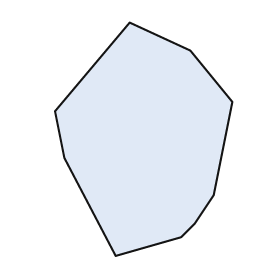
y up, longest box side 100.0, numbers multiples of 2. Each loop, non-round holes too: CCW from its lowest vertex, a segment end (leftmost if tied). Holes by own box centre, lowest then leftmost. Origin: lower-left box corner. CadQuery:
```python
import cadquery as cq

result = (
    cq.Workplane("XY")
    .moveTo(26.0, 0.0)
    .lineTo(54.0, 8.0)
    .lineTo(60.0, 14.0)
    .lineTo(68.0, 26.0)
    .lineTo(76.0, 66.0)
    .lineTo(58.0, 88.0)
    .lineTo(32.0, 100.0)
    .lineTo(0.0, 62.0)
    .lineTo(4.0, 42.0)
    .close()
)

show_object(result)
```